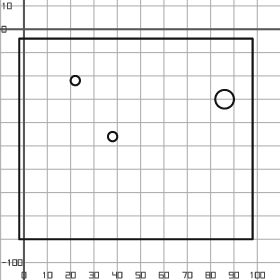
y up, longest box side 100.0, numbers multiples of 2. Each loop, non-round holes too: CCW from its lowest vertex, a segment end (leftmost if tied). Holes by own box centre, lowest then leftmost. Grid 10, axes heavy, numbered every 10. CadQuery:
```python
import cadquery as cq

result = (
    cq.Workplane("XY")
    .moveTo(-2.0, -90.0)
    .lineTo(98.0, -90.0)
    .lineTo(98.0, -4.0)
    .lineTo(-2.0, -4.0)
    .close()
    .moveTo(38.0, -46.0)
    .circle(2.0)
    .moveTo(86.0, -30.0)
    .circle(4.0)
    .moveTo(22.0, -22.0)
    .circle(2.0)
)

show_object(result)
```